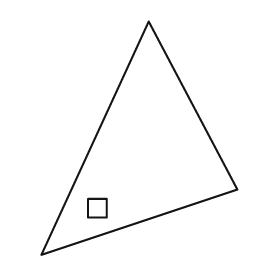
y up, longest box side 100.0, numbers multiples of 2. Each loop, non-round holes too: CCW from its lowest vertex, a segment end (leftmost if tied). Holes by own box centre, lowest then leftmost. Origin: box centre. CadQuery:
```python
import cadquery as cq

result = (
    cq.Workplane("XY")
    .moveTo(-42.0, -50.0)
    .lineTo(42.0, -22.0)
    .lineTo(4.0, 50.0)
    .close()
    .moveTo(-22.0, -34.0)
    .lineTo(-14.0, -34.0)
    .lineTo(-14.0, -26.0)
    .lineTo(-22.0, -26.0)
    .close()
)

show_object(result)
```